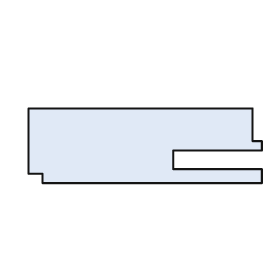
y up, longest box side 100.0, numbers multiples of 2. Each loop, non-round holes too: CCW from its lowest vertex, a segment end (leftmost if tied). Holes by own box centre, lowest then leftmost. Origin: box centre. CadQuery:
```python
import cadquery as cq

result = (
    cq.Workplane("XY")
    .moveTo(-44.0, -16.0)
    .lineTo(50.0, -16.0)
    .lineTo(50.0, -10.0)
    .lineTo(12.0, -10.0)
    .lineTo(12.0, -2.0)
    .lineTo(50.0, -2.0)
    .lineTo(50.0, 2.0)
    .lineTo(46.0, 2.0)
    .lineTo(46.0, 16.0)
    .lineTo(-50.0, 16.0)
    .lineTo(-50.0, -12.0)
    .lineTo(-44.0, -12.0)
    .close()
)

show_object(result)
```